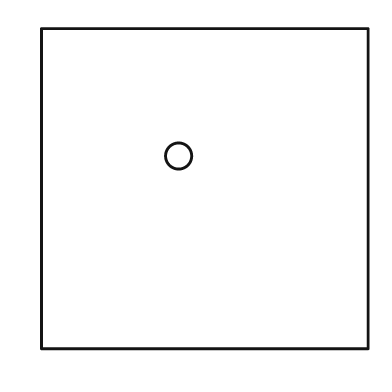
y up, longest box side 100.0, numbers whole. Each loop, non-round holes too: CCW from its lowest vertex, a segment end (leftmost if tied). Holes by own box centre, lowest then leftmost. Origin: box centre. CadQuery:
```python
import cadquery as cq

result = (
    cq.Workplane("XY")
    .moveTo(-50.0, -49.0)
    .lineTo(50.0, -49.0)
    .lineTo(50.0, 49.0)
    .lineTo(-50.0, 49.0)
    .close()
    .moveTo(-8.0, 10.0)
    .circle(4.0)
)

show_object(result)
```